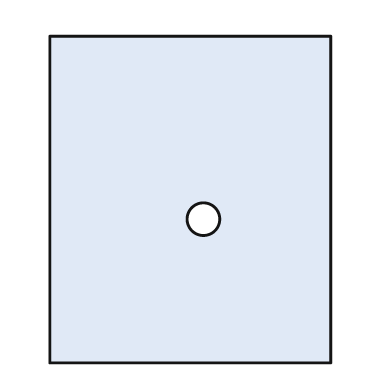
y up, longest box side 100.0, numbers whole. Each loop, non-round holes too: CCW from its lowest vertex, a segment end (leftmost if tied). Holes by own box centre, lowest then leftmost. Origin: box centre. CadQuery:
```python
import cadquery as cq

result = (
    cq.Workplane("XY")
    .moveTo(-43.0, -50.0)
    .lineTo(43.0, -50.0)
    .lineTo(43.0, 50.0)
    .lineTo(-43.0, 50.0)
    .close()
    .moveTo(4.0, -6.0)
    .circle(5.0)
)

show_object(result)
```